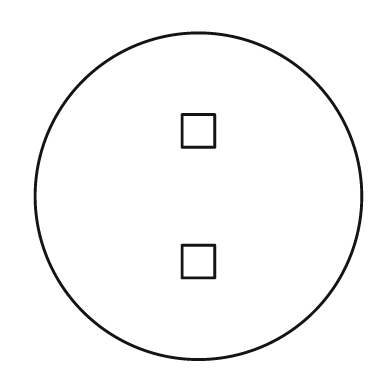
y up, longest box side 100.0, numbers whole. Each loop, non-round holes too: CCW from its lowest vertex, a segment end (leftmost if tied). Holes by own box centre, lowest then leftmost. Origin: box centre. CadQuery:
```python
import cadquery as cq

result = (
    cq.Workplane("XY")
    .moveTo(0.0, 0.0)
    .circle(50.0)
    .moveTo(-5.0, -25.0)
    .lineTo(5.0, -25.0)
    .lineTo(5.0, -15.0)
    .lineTo(-5.0, -15.0)
    .close()
    .moveTo(-5.0, 15.0)
    .lineTo(5.0, 15.0)
    .lineTo(5.0, 25.0)
    .lineTo(-5.0, 25.0)
    .close()
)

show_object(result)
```